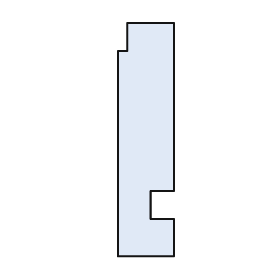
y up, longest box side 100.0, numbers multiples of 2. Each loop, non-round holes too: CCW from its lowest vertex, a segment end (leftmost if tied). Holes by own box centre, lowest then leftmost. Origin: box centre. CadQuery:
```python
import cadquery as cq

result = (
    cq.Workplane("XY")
    .moveTo(-12.0, -50.0)
    .lineTo(12.0, -50.0)
    .lineTo(12.0, -34.0)
    .lineTo(2.0, -34.0)
    .lineTo(2.0, -22.0)
    .lineTo(12.0, -22.0)
    .lineTo(12.0, 50.0)
    .lineTo(-8.0, 50.0)
    .lineTo(-8.0, 38.0)
    .lineTo(-12.0, 38.0)
    .close()
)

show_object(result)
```